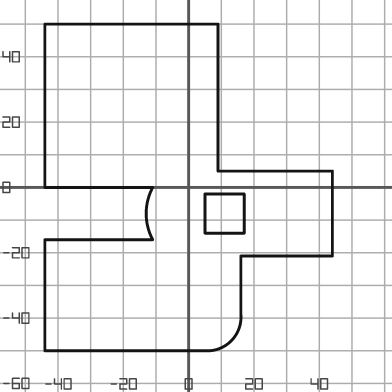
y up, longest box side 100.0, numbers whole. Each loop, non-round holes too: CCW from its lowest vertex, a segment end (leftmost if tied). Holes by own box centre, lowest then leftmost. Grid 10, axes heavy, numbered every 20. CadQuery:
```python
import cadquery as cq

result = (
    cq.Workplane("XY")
    .moveTo(-44.0, -50.0)
    .lineTo(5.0, -50.0)
    .threePointArc((13.0, -47.0), (16.0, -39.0))
    .lineTo(16.0, -21.0)
    .lineTo(44.0, -21.0)
    .lineTo(44.0, 5.0)
    .lineTo(9.0, 5.0)
    .lineTo(9.0, 50.0)
    .lineTo(-44.0, 50.0)
    .lineTo(-44.0, 0.0)
    .lineTo(-11.0, 0.0)
    .threePointArc((-13.0, -8.0), (-11.0, -16.0))
    .lineTo(-44.0, -16.0)
    .close()
    .moveTo(5.0, -14.0)
    .lineTo(17.0, -14.0)
    .lineTo(17.0, -2.0)
    .lineTo(5.0, -2.0)
    .close()
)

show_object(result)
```